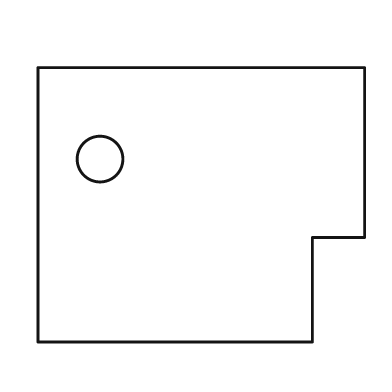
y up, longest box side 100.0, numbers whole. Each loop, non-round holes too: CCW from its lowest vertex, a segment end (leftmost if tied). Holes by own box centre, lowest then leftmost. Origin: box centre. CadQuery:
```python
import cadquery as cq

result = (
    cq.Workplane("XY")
    .moveTo(-50.0, -42.0)
    .lineTo(34.0, -42.0)
    .lineTo(34.0, -10.0)
    .lineTo(50.0, -10.0)
    .lineTo(50.0, 42.0)
    .lineTo(-50.0, 42.0)
    .close()
    .moveTo(-31.0, 14.0)
    .circle(7.0)
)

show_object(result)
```